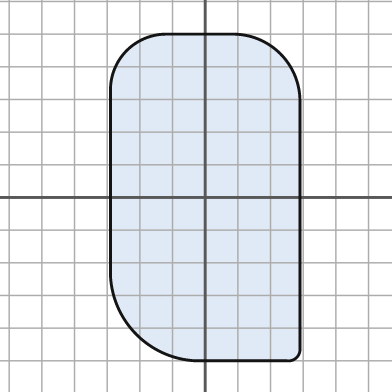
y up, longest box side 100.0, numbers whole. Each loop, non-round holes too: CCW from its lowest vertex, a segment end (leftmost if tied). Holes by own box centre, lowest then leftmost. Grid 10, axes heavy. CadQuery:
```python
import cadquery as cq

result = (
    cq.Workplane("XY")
    .moveTo(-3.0, -50.0)
    .lineTo(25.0, -50.0)
    .threePointArc((28.0, -49.0), (29.0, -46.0))
    .lineTo(29.0, 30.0)
    .threePointArc((23.0, 44.0), (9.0, 50.0))
    .lineTo(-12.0, 50.0)
    .threePointArc((-24.0, 45.0), (-29.0, 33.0))
    .lineTo(-29.0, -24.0)
    .threePointArc((-21.0, -42.0), (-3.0, -50.0))
    .close()
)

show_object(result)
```